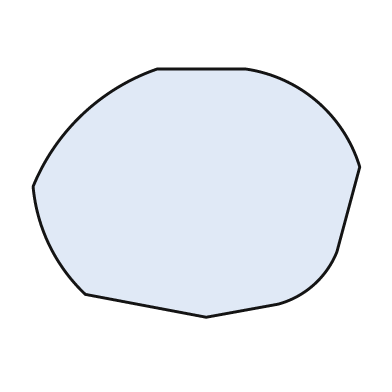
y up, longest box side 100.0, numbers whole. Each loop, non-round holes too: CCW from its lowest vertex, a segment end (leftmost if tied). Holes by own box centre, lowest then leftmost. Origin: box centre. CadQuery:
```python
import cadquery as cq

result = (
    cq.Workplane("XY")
    .moveTo(3.0, -38.0)
    .lineTo(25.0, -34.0)
    .threePointArc((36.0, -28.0), (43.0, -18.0))
    .lineTo(50.0, 8.0)
    .threePointArc((37.0, 28.0), (15.0, 38.0))
    .lineTo(-12.0, 38.0)
    .threePointArc((-35.0, 24.0), (-50.0, 2.0))
    .threePointArc((-45.0, -16.0), (-34.0, -31.0))
    .close()
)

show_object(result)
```